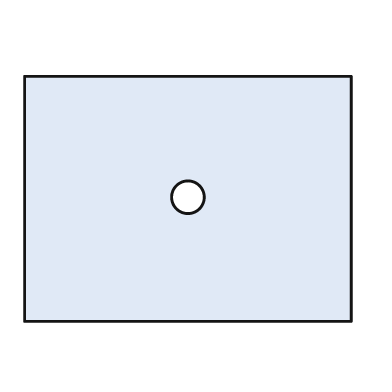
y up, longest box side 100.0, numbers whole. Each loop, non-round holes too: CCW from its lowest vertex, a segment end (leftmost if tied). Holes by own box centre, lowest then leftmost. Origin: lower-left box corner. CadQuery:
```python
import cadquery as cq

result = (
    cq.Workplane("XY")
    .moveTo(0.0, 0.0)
    .lineTo(100.0, 0.0)
    .lineTo(100.0, 75.0)
    .lineTo(0.0, 75.0)
    .close()
    .moveTo(50.0, 38.0)
    .circle(5.0)
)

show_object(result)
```